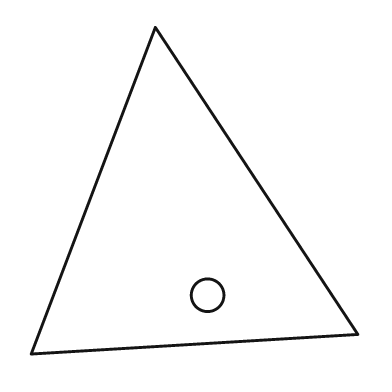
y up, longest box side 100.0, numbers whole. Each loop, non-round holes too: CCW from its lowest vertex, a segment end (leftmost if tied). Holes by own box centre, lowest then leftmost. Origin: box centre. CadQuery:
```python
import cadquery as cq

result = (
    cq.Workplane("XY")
    .moveTo(-50.0, -50.0)
    .lineTo(50.0, -44.0)
    .lineTo(-12.0, 50.0)
    .close()
    .moveTo(4.0, -32.0)
    .circle(5.0)
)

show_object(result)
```